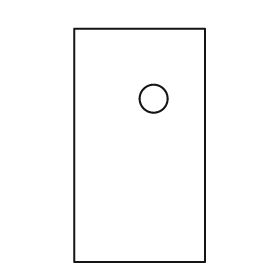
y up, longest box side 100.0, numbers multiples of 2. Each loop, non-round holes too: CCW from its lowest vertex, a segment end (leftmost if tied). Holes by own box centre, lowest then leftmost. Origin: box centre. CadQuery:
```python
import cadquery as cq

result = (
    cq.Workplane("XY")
    .moveTo(-28.0, -50.0)
    .lineTo(28.0, -50.0)
    .lineTo(28.0, 50.0)
    .lineTo(-28.0, 50.0)
    .close()
    .moveTo(6.0, 20.0)
    .circle(6.0)
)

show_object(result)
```